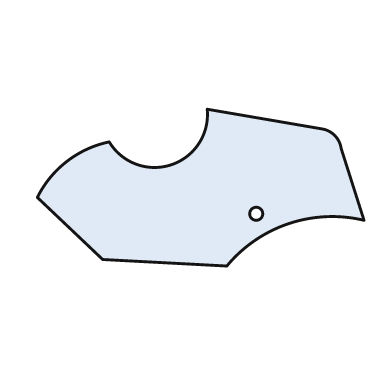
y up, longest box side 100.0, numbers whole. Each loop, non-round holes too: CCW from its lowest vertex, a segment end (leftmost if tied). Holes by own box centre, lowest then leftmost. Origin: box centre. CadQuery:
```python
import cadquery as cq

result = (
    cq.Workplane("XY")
    .moveTo(8.0, -24.0)
    .threePointArc((27.0, -11.0), (50.0, -10.0))
    .lineTo(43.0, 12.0)
    .threePointArc((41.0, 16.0), (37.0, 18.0))
    .lineTo(2.0, 24.0)
    .threePointArc((-9.0, 7.0), (-28.0, 14.0))
    .threePointArc((-41.0, 8.0), (-50.0, -3.0))
    .lineTo(-30.0, -22.0)
    .close()
    .moveTo(17.0, -8.0)
    .circle(2.0)
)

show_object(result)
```